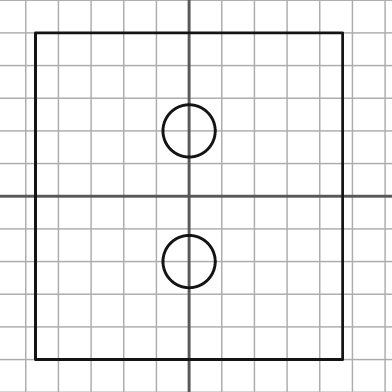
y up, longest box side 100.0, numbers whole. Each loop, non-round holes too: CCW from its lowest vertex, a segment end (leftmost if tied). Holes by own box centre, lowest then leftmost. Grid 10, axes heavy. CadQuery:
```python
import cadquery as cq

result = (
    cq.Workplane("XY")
    .moveTo(-47.0, -50.0)
    .lineTo(47.0, -50.0)
    .lineTo(47.0, 50.0)
    .lineTo(-47.0, 50.0)
    .close()
    .moveTo(0.0, -20.0)
    .circle(8.0)
    .moveTo(0.0, 20.0)
    .circle(8.0)
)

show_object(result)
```